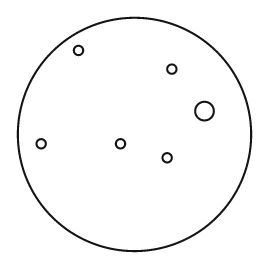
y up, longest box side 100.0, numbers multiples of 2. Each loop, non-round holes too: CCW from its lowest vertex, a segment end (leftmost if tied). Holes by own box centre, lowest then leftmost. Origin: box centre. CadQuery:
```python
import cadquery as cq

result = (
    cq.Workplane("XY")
    .moveTo(0.0, 0.0)
    .circle(50.0)
    .moveTo(14.0, -10.0)
    .circle(2.0)
    .moveTo(-40.0, -4.0)
    .circle(2.0)
    .moveTo(-6.0, -4.0)
    .circle(2.0)
    .moveTo(30.0, 10.0)
    .circle(4.0)
    .moveTo(16.0, 28.0)
    .circle(2.0)
    .moveTo(-24.0, 36.0)
    .circle(2.0)
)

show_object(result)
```